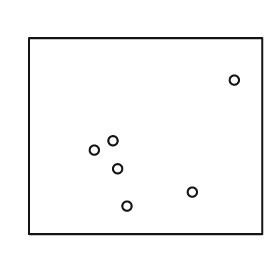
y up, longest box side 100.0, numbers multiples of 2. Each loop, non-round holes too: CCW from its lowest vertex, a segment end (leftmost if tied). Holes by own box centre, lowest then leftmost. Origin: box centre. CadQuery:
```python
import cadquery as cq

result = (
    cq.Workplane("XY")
    .moveTo(-50.0, -42.0)
    .lineTo(50.0, -42.0)
    .lineTo(50.0, 42.0)
    .lineTo(-50.0, 42.0)
    .close()
    .moveTo(-8.0, -30.0)
    .circle(2.0)
    .moveTo(20.0, -24.0)
    .circle(2.0)
    .moveTo(-12.0, -14.0)
    .circle(2.0)
    .moveTo(-22.0, -6.0)
    .circle(2.0)
    .moveTo(-14.0, -2.0)
    .circle(2.0)
    .moveTo(38.0, 24.0)
    .circle(2.0)
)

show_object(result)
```